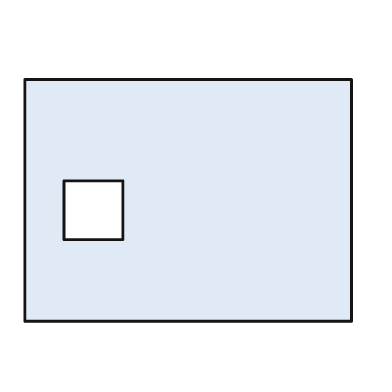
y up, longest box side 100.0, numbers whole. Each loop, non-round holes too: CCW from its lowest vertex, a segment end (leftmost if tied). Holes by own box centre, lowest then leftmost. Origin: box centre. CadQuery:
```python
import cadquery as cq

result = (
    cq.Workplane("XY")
    .moveTo(-50.0, -37.0)
    .lineTo(50.0, -37.0)
    .lineTo(50.0, 37.0)
    .lineTo(-50.0, 37.0)
    .close()
    .moveTo(-38.0, -12.0)
    .lineTo(-20.0, -12.0)
    .lineTo(-20.0, 6.0)
    .lineTo(-38.0, 6.0)
    .close()
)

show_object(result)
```